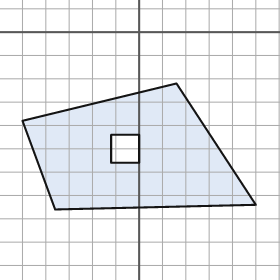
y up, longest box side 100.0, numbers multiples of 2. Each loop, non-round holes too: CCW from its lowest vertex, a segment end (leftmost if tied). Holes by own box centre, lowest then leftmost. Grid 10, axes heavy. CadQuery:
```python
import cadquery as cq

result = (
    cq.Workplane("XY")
    .moveTo(-36.0, -76.0)
    .lineTo(50.0, -74.0)
    .lineTo(16.0, -22.0)
    .lineTo(-50.0, -38.0)
    .close()
    .moveTo(-12.0, -56.0)
    .lineTo(0.0, -56.0)
    .lineTo(0.0, -44.0)
    .lineTo(-12.0, -44.0)
    .close()
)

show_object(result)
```